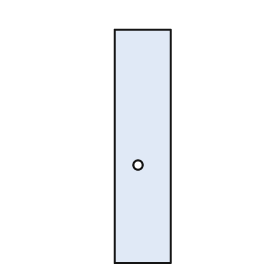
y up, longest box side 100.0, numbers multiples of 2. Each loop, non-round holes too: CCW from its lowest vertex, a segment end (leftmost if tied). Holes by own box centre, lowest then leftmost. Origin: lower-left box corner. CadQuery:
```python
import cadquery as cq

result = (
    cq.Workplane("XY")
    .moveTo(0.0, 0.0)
    .lineTo(24.0, 0.0)
    .lineTo(24.0, 100.0)
    .lineTo(0.0, 100.0)
    .close()
    .moveTo(10.0, 42.0)
    .circle(2.0)
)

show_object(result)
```